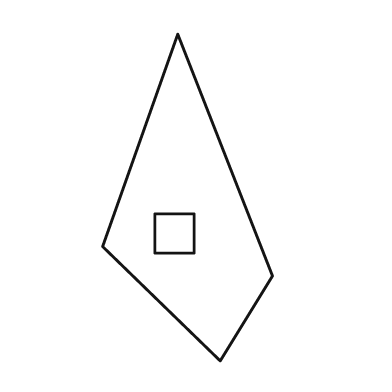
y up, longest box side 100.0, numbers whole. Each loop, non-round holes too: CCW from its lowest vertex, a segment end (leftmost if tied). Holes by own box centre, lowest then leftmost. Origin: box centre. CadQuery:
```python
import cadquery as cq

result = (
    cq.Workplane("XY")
    .moveTo(10.0, -50.0)
    .lineTo(26.0, -24.0)
    .lineTo(-3.0, 50.0)
    .lineTo(-26.0, -15.0)
    .close()
    .moveTo(-10.0, -17.0)
    .lineTo(2.0, -17.0)
    .lineTo(2.0, -5.0)
    .lineTo(-10.0, -5.0)
    .close()
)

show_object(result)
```